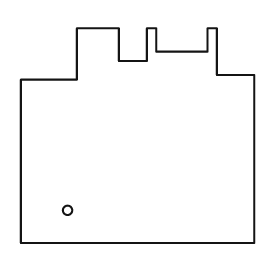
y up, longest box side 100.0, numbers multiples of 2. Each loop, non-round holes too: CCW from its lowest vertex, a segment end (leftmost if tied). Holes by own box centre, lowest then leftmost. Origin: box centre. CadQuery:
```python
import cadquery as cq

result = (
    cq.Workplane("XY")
    .moveTo(-50.0, -46.0)
    .lineTo(50.0, -46.0)
    .lineTo(50.0, 26.0)
    .lineTo(34.0, 26.0)
    .lineTo(34.0, 46.0)
    .lineTo(30.0, 46.0)
    .lineTo(30.0, 36.0)
    .lineTo(8.0, 36.0)
    .lineTo(8.0, 46.0)
    .lineTo(4.0, 46.0)
    .lineTo(4.0, 32.0)
    .lineTo(-8.0, 32.0)
    .lineTo(-8.0, 46.0)
    .lineTo(-26.0, 46.0)
    .lineTo(-26.0, 24.0)
    .lineTo(-50.0, 24.0)
    .close()
    .moveTo(-30.0, -32.0)
    .circle(2.0)
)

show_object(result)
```